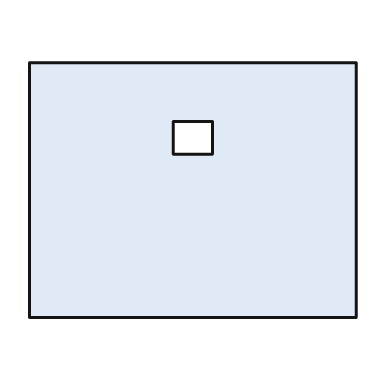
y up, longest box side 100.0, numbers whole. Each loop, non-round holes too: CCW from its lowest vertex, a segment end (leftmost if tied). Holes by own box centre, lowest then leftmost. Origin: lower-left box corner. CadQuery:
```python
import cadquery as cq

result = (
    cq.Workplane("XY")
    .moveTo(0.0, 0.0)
    .lineTo(100.0, 0.0)
    .lineTo(100.0, 78.0)
    .lineTo(0.0, 78.0)
    .close()
    .moveTo(44.0, 50.0)
    .lineTo(56.0, 50.0)
    .lineTo(56.0, 60.0)
    .lineTo(44.0, 60.0)
    .close()
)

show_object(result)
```